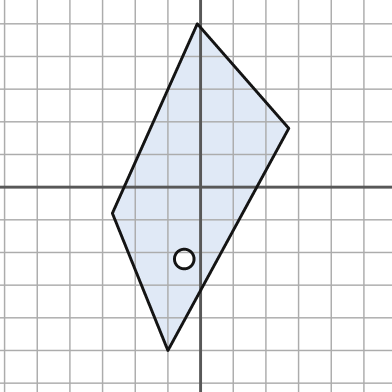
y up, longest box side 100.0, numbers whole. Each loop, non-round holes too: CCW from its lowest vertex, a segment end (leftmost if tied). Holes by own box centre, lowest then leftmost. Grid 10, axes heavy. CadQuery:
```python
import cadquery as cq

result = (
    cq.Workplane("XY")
    .moveTo(-10.0, -50.0)
    .lineTo(27.0, 18.0)
    .lineTo(-1.0, 50.0)
    .lineTo(-27.0, -8.0)
    .close()
    .moveTo(-5.0, -22.0)
    .circle(3.0)
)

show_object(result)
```